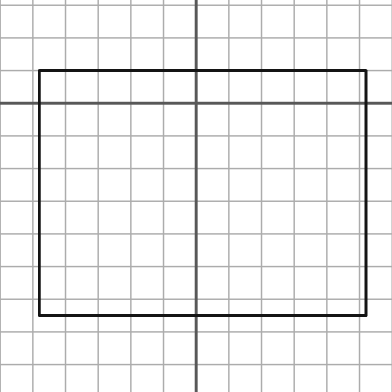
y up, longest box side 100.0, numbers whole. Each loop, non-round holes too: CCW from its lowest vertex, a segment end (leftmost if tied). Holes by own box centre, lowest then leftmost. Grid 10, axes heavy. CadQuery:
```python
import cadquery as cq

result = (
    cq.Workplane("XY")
    .moveTo(-48.0, -65.0)
    .lineTo(52.0, -65.0)
    .lineTo(52.0, 10.0)
    .lineTo(-48.0, 10.0)
    .close()
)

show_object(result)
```